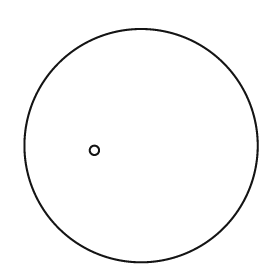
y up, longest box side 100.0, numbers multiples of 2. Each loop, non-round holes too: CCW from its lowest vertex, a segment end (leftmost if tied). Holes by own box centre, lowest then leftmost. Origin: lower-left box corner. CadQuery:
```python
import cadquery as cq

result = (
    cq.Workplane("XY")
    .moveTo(50.0, 50.0)
    .circle(50.0)
    .moveTo(30.0, 48.0)
    .circle(2.0)
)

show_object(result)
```